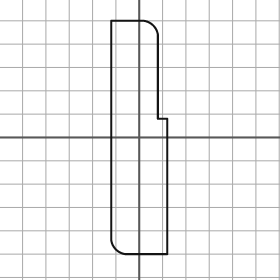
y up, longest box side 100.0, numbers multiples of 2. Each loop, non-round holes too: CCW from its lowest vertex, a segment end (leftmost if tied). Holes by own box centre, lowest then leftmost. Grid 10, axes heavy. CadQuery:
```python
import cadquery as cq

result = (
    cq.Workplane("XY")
    .moveTo(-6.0, -50.0)
    .lineTo(12.0, -50.0)
    .lineTo(12.0, 8.0)
    .lineTo(8.0, 8.0)
    .lineTo(8.0, 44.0)
    .threePointArc((6.0, 48.0), (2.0, 50.0))
    .lineTo(-12.0, 50.0)
    .lineTo(-12.0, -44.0)
    .threePointArc((-10.0, -48.0), (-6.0, -50.0))
    .close()
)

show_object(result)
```